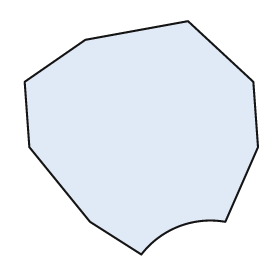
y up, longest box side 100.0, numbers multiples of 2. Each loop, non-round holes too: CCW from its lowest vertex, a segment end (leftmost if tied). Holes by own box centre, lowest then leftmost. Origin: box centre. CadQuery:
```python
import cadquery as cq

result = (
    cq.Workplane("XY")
    .moveTo(0.0, -50.0)
    .threePointArc((16.0, -38.0), (36.0, -36.0))
    .lineTo(50.0, -4.0)
    .lineTo(48.0, 24.0)
    .lineTo(20.0, 50.0)
    .lineTo(-24.0, 42.0)
    .lineTo(-50.0, 24.0)
    .lineTo(-48.0, -4.0)
    .lineTo(-22.0, -36.0)
    .close()
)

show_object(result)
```